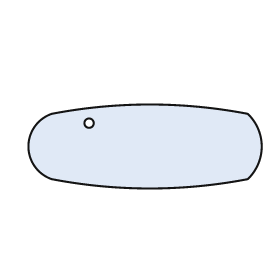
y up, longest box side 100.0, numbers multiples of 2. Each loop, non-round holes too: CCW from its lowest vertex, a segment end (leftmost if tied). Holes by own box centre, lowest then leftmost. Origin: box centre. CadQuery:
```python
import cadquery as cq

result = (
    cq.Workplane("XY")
    .moveTo(-40.0, -14.0)
    .threePointArc((2.0, -18.0), (44.0, -14.0))
    .threePointArc((50.0, 0.0), (44.0, 14.0))
    .threePointArc((2.0, 18.0), (-40.0, 14.0))
    .threePointArc((-50.0, 0.0), (-40.0, -14.0))
    .close()
    .moveTo(-24.0, 10.0)
    .circle(2.0)
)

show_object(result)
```